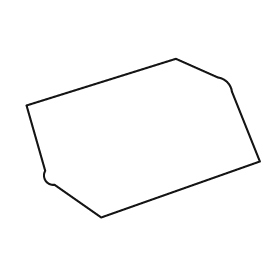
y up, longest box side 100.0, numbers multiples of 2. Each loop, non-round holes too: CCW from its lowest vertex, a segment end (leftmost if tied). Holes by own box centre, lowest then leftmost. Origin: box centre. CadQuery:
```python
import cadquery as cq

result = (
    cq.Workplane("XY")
    .moveTo(-18.0, -34.0)
    .lineTo(50.0, -10.0)
    .lineTo(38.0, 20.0)
    .threePointArc((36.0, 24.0), (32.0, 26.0))
    .lineTo(14.0, 34.0)
    .lineTo(-50.0, 14.0)
    .lineTo(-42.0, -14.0)
    .threePointArc((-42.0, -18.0), (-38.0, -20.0))
    .close()
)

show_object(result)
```